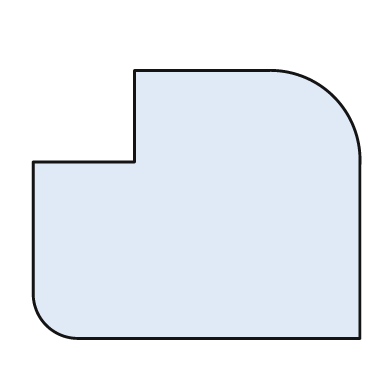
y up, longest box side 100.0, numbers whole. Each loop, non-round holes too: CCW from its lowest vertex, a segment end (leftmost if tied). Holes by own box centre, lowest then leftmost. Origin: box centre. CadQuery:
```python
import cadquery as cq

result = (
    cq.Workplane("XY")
    .moveTo(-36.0, -41.0)
    .lineTo(50.0, -41.0)
    .lineTo(50.0, 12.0)
    .threePointArc((42.0, 33.0), (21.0, 41.0))
    .lineTo(-19.0, 41.0)
    .lineTo(-19.0, 13.0)
    .lineTo(-50.0, 13.0)
    .lineTo(-50.0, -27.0)
    .threePointArc((-46.0, -37.0), (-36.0, -41.0))
    .close()
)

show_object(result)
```